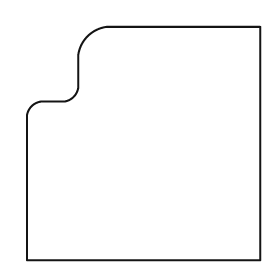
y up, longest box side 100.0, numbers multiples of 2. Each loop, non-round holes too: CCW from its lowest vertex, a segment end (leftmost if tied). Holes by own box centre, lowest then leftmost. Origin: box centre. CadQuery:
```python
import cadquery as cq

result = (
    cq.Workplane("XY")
    .moveTo(-50.0, -50.0)
    .lineTo(50.0, -50.0)
    .lineTo(50.0, 50.0)
    .lineTo(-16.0, 50.0)
    .threePointArc((-24.0, 46.0), (-28.0, 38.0))
    .lineTo(-28.0, 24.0)
    .threePointArc((-30.0, 20.0), (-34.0, 18.0))
    .lineTo(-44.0, 18.0)
    .threePointArc((-48.0, 16.0), (-50.0, 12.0))
    .close()
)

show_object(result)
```